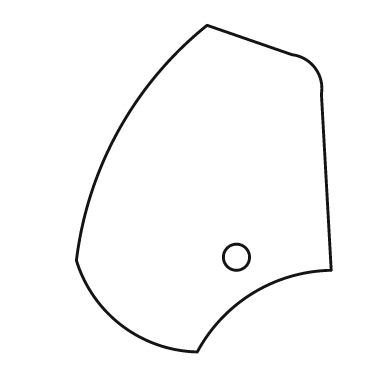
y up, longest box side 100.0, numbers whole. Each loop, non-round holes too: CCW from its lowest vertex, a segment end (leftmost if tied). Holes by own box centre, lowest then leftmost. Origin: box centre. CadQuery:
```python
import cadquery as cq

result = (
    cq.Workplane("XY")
    .moveTo(-2.0, -50.0)
    .threePointArc((15.0, -32.0), (39.0, -25.0))
    .lineTo(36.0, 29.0)
    .threePointArc((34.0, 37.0), (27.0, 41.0))
    .lineTo(1.0, 50.0)
    .threePointArc((-26.0, 18.0), (-39.0, -22.0))
    .threePointArc((-25.0, -42.0), (-2.0, -50.0))
    .close()
    .moveTo(10.0, -21.0)
    .circle(4.0)
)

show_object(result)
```